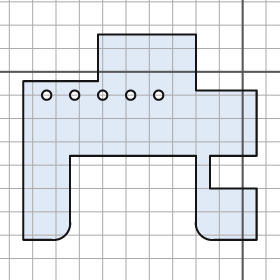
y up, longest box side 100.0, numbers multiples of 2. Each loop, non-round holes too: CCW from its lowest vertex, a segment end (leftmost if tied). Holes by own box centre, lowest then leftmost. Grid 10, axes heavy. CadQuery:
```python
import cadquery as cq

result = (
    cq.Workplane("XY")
    .moveTo(-94.0, -72.0)
    .lineTo(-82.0, -72.0)
    .threePointArc((-76.0, -70.0), (-74.0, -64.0))
    .lineTo(-74.0, -36.0)
    .lineTo(-20.0, -36.0)
    .lineTo(-20.0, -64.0)
    .threePointArc((-18.0, -70.0), (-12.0, -72.0))
    .lineTo(6.0, -72.0)
    .lineTo(6.0, -50.0)
    .lineTo(-14.0, -50.0)
    .lineTo(-14.0, -36.0)
    .lineTo(6.0, -36.0)
    .lineTo(6.0, -8.0)
    .lineTo(-20.0, -8.0)
    .lineTo(-20.0, 16.0)
    .lineTo(-62.0, 16.0)
    .lineTo(-62.0, -4.0)
    .lineTo(-94.0, -4.0)
    .close()
    .moveTo(-84.0, -10.0)
    .circle(2.0)
    .moveTo(-72.0, -10.0)
    .circle(2.0)
    .moveTo(-60.0, -10.0)
    .circle(2.0)
    .moveTo(-48.0, -10.0)
    .circle(2.0)
    .moveTo(-36.0, -10.0)
    .circle(2.0)
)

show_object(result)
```